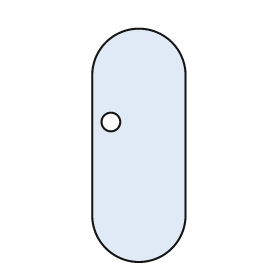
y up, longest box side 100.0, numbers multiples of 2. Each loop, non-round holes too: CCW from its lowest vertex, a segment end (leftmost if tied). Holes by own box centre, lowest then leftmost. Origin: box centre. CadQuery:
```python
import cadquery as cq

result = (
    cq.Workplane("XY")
    .moveTo(-20.0, -30.0)
    .threePointArc((0.0, -50.0), (20.0, -30.0))
    .lineTo(20.0, 30.0)
    .threePointArc((0.0, 50.0), (-20.0, 30.0))
    .close()
    .moveTo(-12.0, 10.0)
    .circle(4.0)
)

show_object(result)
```